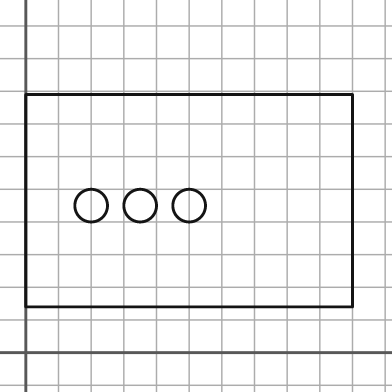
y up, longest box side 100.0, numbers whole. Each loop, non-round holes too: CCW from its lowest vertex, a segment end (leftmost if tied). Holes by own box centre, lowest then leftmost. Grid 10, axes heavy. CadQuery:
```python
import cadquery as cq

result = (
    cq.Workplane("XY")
    .moveTo(0.0, 14.0)
    .lineTo(100.0, 14.0)
    .lineTo(100.0, 79.0)
    .lineTo(0.0, 79.0)
    .close()
    .moveTo(20.0, 45.0)
    .circle(5.0)
    .moveTo(35.0, 45.0)
    .circle(5.0)
    .moveTo(50.0, 45.0)
    .circle(5.0)
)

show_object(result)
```